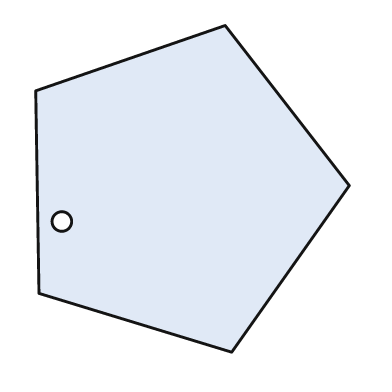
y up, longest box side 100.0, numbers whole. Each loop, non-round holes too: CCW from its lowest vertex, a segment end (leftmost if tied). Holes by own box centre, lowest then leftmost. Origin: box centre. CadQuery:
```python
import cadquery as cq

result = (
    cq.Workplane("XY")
    .moveTo(12.0, -50.0)
    .lineTo(48.0, 1.0)
    .lineTo(10.0, 50.0)
    .lineTo(-48.0, 30.0)
    .lineTo(-47.0, -32.0)
    .close()
    .moveTo(-40.0, -10.0)
    .circle(3.0)
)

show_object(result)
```